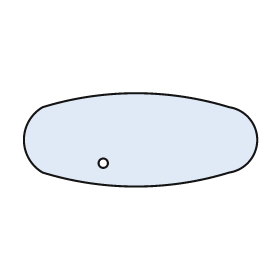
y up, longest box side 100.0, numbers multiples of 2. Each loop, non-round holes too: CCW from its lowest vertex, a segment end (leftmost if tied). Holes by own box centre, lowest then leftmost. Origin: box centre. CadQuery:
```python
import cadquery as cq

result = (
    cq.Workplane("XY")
    .moveTo(-42.0, -14.0)
    .threePointArc((-2.0, -20.0), (38.0, -14.0))
    .threePointArc((50.0, 0.0), (38.0, 14.0))
    .threePointArc((-2.0, 20.0), (-42.0, 14.0))
    .threePointArc((-50.0, 0.0), (-42.0, -14.0))
    .close()
    .moveTo(-16.0, -10.0)
    .circle(2.0)
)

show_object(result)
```